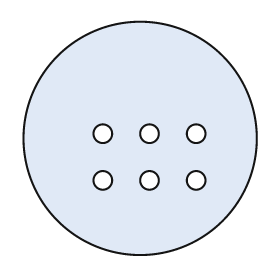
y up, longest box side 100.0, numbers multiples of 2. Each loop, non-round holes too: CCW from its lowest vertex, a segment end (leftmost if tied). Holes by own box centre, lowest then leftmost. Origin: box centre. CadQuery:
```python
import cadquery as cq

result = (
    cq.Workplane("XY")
    .moveTo(0.0, 0.0)
    .circle(50.0)
    .moveTo(-16.0, -18.0)
    .circle(4.0)
    .moveTo(4.0, -18.0)
    .circle(4.0)
    .moveTo(24.0, -18.0)
    .circle(4.0)
    .moveTo(-16.0, 2.0)
    .circle(4.0)
    .moveTo(4.0, 2.0)
    .circle(4.0)
    .moveTo(24.0, 2.0)
    .circle(4.0)
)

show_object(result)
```